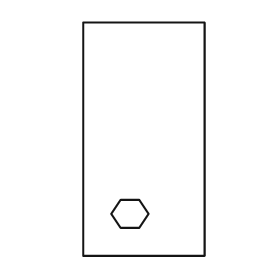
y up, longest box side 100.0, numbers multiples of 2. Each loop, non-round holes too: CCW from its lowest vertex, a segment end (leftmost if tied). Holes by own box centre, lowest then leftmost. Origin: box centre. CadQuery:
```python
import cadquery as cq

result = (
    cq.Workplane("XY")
    .moveTo(-26.0, -50.0)
    .lineTo(26.0, -50.0)
    .lineTo(26.0, 50.0)
    .lineTo(-26.0, 50.0)
    .close()
    .moveTo(-10.0, -38.0)
    .lineTo(-2.0, -38.0)
    .lineTo(2.0, -32.0)
    .lineTo(-2.0, -26.0)
    .lineTo(-10.0, -26.0)
    .lineTo(-14.0, -32.0)
    .close()
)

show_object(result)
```